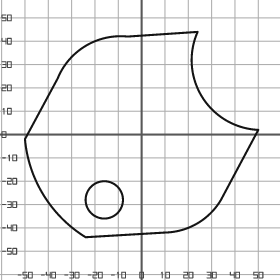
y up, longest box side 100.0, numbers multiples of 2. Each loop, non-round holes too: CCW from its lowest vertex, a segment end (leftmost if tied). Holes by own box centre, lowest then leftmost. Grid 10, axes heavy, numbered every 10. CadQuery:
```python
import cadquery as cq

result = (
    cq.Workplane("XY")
    .moveTo(-24.0, -44.0)
    .lineTo(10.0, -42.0)
    .threePointArc((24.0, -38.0), (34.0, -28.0))
    .lineTo(50.0, 2.0)
    .threePointArc((26.0, 16.0), (24.0, 44.0))
    .lineTo(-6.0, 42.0)
    .threePointArc((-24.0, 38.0), (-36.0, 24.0))
    .lineTo(-50.0, -2.0)
    .threePointArc((-42.0, -26.0), (-24.0, -44.0))
    .close()
    .moveTo(-16.0, -28.0)
    .circle(8.0)
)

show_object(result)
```